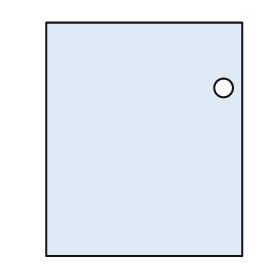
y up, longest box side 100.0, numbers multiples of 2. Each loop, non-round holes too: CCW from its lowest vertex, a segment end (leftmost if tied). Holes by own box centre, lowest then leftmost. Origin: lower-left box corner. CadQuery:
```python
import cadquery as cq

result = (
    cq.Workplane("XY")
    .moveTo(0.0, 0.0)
    .lineTo(84.0, 0.0)
    .lineTo(84.0, 100.0)
    .lineTo(0.0, 100.0)
    .close()
    .moveTo(76.0, 72.0)
    .circle(4.0)
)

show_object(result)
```